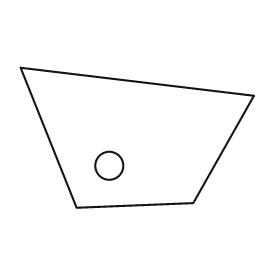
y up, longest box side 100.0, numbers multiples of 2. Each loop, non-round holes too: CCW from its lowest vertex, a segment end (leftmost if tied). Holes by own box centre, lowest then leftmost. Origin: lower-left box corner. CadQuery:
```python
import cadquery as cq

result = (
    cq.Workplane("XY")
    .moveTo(24.0, 0.0)
    .lineTo(74.0, 2.0)
    .lineTo(100.0, 48.0)
    .lineTo(0.0, 60.0)
    .close()
    .moveTo(38.0, 18.0)
    .circle(6.0)
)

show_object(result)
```